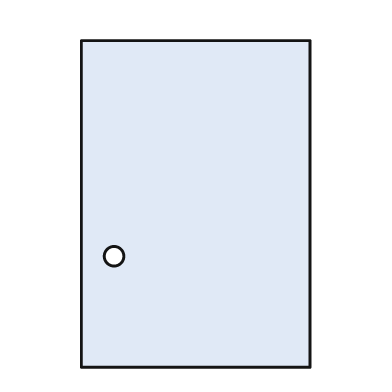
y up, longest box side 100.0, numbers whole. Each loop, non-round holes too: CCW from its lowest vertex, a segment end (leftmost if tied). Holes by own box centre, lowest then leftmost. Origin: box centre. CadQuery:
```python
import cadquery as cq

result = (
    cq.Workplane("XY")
    .moveTo(-35.0, -50.0)
    .lineTo(35.0, -50.0)
    .lineTo(35.0, 50.0)
    .lineTo(-35.0, 50.0)
    .close()
    .moveTo(-25.0, -16.0)
    .circle(3.0)
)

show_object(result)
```